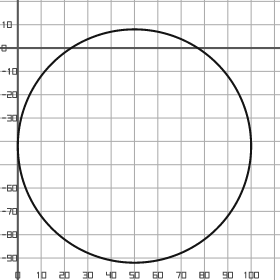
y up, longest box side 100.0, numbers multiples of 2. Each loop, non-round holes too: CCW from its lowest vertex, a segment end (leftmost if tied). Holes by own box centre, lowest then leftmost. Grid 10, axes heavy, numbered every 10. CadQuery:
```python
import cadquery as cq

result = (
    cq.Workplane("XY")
    .moveTo(50.0, -42.0)
    .circle(50.0)
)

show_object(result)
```